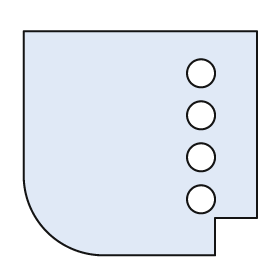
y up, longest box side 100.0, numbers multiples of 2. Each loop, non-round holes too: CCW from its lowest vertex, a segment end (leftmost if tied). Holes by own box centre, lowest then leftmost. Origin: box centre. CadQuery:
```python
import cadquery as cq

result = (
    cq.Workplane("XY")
    .moveTo(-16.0, -48.0)
    .lineTo(32.0, -48.0)
    .lineTo(32.0, -32.0)
    .lineTo(50.0, -32.0)
    .lineTo(50.0, 48.0)
    .lineTo(-50.0, 48.0)
    .lineTo(-50.0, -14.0)
    .threePointArc((-40.0, -38.0), (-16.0, -48.0))
    .close()
    .moveTo(26.0, -24.0)
    .circle(6.0)
    .moveTo(26.0, -6.0)
    .circle(6.0)
    .moveTo(26.0, 12.0)
    .circle(6.0)
    .moveTo(26.0, 30.0)
    .circle(6.0)
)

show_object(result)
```